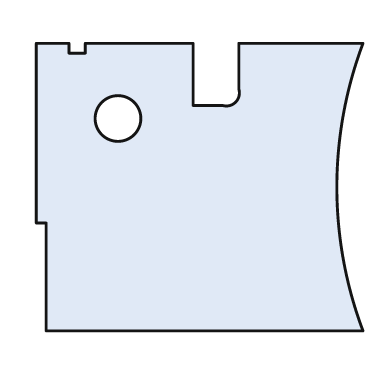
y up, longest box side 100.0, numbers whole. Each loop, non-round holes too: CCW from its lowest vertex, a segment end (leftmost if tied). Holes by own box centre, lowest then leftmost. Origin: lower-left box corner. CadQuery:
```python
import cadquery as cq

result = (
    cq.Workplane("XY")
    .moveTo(3.0, 0.0)
    .lineTo(100.0, 0.0)
    .threePointArc((92.0, 44.0), (100.0, 88.0))
    .lineTo(62.0, 88.0)
    .lineTo(62.0, 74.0)
    .threePointArc((61.0, 70.0), (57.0, 69.0))
    .lineTo(48.0, 69.0)
    .lineTo(48.0, 88.0)
    .lineTo(15.0, 88.0)
    .lineTo(15.0, 85.0)
    .lineTo(10.0, 85.0)
    .lineTo(10.0, 88.0)
    .lineTo(0.0, 88.0)
    .lineTo(0.0, 33.0)
    .lineTo(3.0, 33.0)
    .close()
    .moveTo(25.0, 65.0)
    .circle(7.0)
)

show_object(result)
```